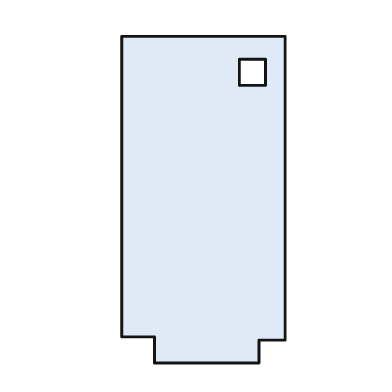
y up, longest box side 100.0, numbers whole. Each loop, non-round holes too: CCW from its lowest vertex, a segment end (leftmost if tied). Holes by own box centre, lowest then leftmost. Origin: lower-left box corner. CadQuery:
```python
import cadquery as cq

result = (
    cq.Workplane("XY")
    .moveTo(10.0, 0.0)
    .lineTo(42.0, 0.0)
    .lineTo(42.0, 7.0)
    .lineTo(50.0, 7.0)
    .lineTo(50.0, 100.0)
    .lineTo(0.0, 100.0)
    .lineTo(0.0, 8.0)
    .lineTo(10.0, 8.0)
    .close()
    .moveTo(36.0, 85.0)
    .lineTo(44.0, 85.0)
    .lineTo(44.0, 93.0)
    .lineTo(36.0, 93.0)
    .close()
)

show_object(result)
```